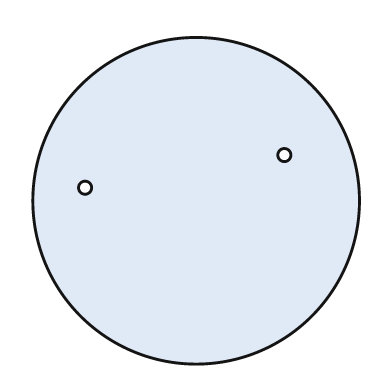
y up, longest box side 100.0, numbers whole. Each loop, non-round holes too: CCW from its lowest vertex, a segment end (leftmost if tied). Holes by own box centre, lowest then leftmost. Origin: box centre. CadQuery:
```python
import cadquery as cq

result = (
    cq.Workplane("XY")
    .moveTo(0.0, 0.0)
    .circle(50.0)
    .moveTo(-34.0, 4.0)
    .circle(2.0)
    .moveTo(27.0, 14.0)
    .circle(2.0)
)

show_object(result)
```